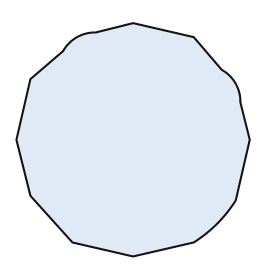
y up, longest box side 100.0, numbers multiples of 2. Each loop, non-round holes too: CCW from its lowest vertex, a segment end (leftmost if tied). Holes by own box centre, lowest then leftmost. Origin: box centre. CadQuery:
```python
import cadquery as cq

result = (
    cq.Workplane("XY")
    .moveTo(0.0, -50.0)
    .lineTo(26.0, -44.0)
    .threePointArc((36.0, -36.0), (44.0, -26.0))
    .lineTo(50.0, 0.0)
    .lineTo(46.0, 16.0)
    .threePointArc((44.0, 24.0), (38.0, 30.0))
    .lineTo(26.0, 44.0)
    .lineTo(0.0, 50.0)
    .lineTo(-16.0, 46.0)
    .threePointArc((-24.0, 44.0), (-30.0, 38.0))
    .lineTo(-44.0, 26.0)
    .lineTo(-50.0, 0.0)
    .lineTo(-44.0, -24.0)
    .lineTo(-26.0, -44.0)
    .close()
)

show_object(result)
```